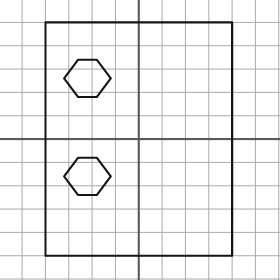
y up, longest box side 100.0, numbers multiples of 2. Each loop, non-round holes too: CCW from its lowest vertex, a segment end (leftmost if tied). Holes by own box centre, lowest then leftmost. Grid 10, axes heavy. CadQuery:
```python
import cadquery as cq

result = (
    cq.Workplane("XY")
    .moveTo(-40.0, -50.0)
    .lineTo(40.0, -50.0)
    .lineTo(40.0, 50.0)
    .lineTo(-40.0, 50.0)
    .close()
    .moveTo(-26.0, -24.0)
    .lineTo(-18.0, -24.0)
    .lineTo(-12.0, -16.0)
    .lineTo(-18.0, -8.0)
    .lineTo(-26.0, -8.0)
    .lineTo(-32.0, -16.0)
    .close()
    .moveTo(-26.0, 18.0)
    .lineTo(-18.0, 18.0)
    .lineTo(-12.0, 26.0)
    .lineTo(-18.0, 34.0)
    .lineTo(-26.0, 34.0)
    .lineTo(-32.0, 26.0)
    .close()
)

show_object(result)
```